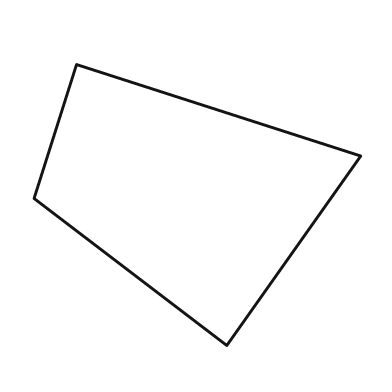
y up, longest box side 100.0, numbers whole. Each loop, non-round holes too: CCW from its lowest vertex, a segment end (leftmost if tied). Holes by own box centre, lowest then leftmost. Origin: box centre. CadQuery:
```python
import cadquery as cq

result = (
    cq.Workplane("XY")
    .moveTo(9.0, -43.0)
    .lineTo(50.0, 15.0)
    .lineTo(-37.0, 43.0)
    .lineTo(-50.0, 2.0)
    .close()
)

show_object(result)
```